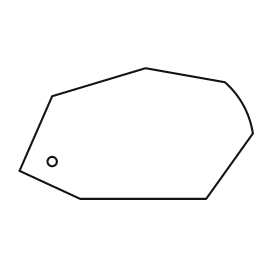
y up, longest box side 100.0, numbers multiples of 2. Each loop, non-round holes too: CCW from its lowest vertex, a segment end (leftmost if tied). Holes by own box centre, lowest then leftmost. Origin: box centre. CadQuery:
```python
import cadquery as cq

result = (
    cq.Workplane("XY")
    .moveTo(-24.0, -28.0)
    .lineTo(30.0, -28.0)
    .lineTo(50.0, 0.0)
    .threePointArc((46.0, 12.0), (38.0, 22.0))
    .lineTo(4.0, 28.0)
    .lineTo(-36.0, 16.0)
    .lineTo(-50.0, -16.0)
    .close()
    .moveTo(-36.0, -12.0)
    .circle(2.0)
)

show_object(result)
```